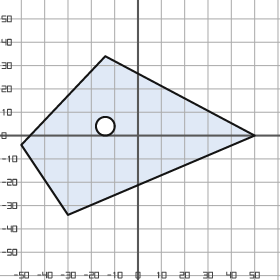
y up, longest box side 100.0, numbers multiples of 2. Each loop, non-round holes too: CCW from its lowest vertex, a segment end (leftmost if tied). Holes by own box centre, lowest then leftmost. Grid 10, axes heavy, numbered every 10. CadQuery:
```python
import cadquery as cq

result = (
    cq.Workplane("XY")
    .moveTo(-30.0, -34.0)
    .lineTo(50.0, 0.0)
    .lineTo(-14.0, 34.0)
    .lineTo(-50.0, -4.0)
    .close()
    .moveTo(-14.0, 4.0)
    .circle(4.0)
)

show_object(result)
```